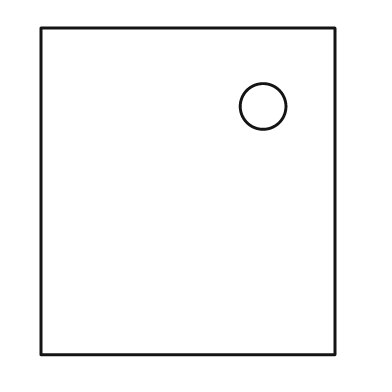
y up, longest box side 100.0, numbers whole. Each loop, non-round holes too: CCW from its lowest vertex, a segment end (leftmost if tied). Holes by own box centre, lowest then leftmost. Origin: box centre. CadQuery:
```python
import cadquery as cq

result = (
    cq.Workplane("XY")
    .moveTo(-45.0, -50.0)
    .lineTo(45.0, -50.0)
    .lineTo(45.0, 50.0)
    .lineTo(-45.0, 50.0)
    .close()
    .moveTo(23.0, 26.0)
    .circle(7.0)
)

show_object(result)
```